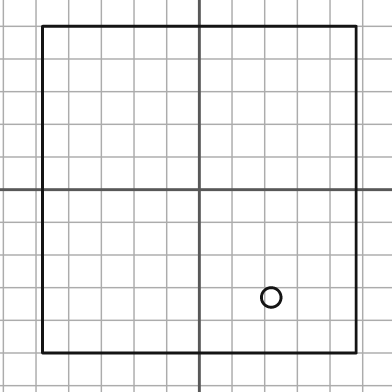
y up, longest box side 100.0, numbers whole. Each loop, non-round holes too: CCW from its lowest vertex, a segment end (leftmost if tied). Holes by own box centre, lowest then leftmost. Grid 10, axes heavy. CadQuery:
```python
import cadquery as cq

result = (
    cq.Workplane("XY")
    .moveTo(-48.0, -50.0)
    .lineTo(48.0, -50.0)
    .lineTo(48.0, 50.0)
    .lineTo(-48.0, 50.0)
    .close()
    .moveTo(22.0, -33.0)
    .circle(3.0)
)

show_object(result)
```